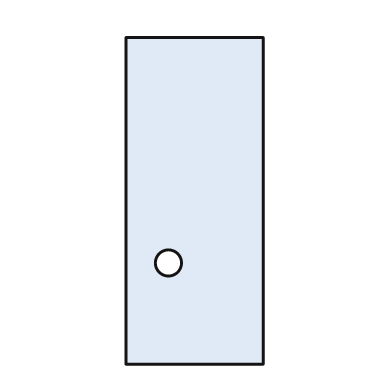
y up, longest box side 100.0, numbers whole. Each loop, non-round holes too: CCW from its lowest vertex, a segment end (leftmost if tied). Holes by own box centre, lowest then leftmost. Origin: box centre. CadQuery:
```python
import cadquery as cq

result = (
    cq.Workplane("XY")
    .moveTo(-21.0, -50.0)
    .lineTo(21.0, -50.0)
    .lineTo(21.0, 50.0)
    .lineTo(-21.0, 50.0)
    .close()
    .moveTo(-8.0, -19.0)
    .circle(4.0)
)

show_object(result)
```